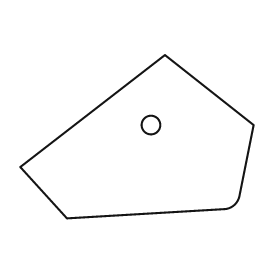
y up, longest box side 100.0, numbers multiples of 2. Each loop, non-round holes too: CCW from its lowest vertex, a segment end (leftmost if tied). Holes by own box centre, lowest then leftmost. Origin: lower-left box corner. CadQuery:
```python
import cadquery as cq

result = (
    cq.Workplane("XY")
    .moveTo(20.0, 0.0)
    .lineTo(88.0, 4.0)
    .threePointArc((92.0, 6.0), (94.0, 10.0))
    .lineTo(100.0, 40.0)
    .lineTo(62.0, 70.0)
    .lineTo(0.0, 22.0)
    .close()
    .moveTo(56.0, 40.0)
    .circle(4.0)
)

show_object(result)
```